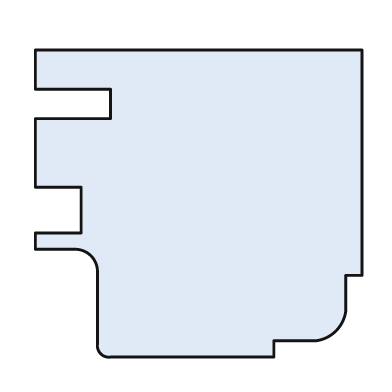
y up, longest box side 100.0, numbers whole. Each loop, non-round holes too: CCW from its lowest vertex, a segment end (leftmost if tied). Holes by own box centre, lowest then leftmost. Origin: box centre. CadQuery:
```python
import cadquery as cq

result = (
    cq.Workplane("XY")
    .moveTo(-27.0, -47.0)
    .lineTo(23.0, -47.0)
    .lineTo(23.0, -42.0)
    .lineTo(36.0, -42.0)
    .threePointArc((42.0, -39.0), (45.0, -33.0))
    .lineTo(45.0, -22.0)
    .lineTo(50.0, -22.0)
    .lineTo(50.0, 47.0)
    .lineTo(-50.0, 47.0)
    .lineTo(-50.0, 35.0)
    .lineTo(-27.0, 35.0)
    .lineTo(-27.0, 26.0)
    .lineTo(-50.0, 26.0)
    .lineTo(-50.0, 5.0)
    .lineTo(-36.0, 5.0)
    .lineTo(-36.0, -9.0)
    .lineTo(-50.0, -9.0)
    .lineTo(-50.0, -14.0)
    .lineTo(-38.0, -14.0)
    .threePointArc((-33.0, -16.0), (-31.0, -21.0))
    .lineTo(-31.0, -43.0)
    .threePointArc((-30.0, -46.0), (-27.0, -47.0))
    .close()
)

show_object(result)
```